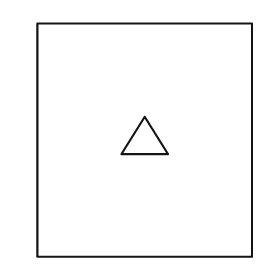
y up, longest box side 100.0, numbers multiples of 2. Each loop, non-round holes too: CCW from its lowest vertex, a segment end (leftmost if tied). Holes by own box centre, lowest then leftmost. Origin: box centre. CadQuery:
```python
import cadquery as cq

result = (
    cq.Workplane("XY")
    .moveTo(-46.0, -50.0)
    .lineTo(46.0, -50.0)
    .lineTo(46.0, 50.0)
    .lineTo(-46.0, 50.0)
    .close()
    .moveTo(-10.0, -6.0)
    .lineTo(10.0, -6.0)
    .lineTo(0.0, 10.0)
    .close()
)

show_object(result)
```